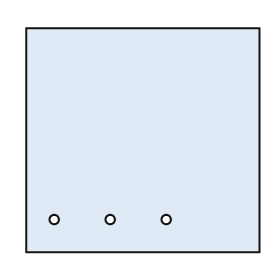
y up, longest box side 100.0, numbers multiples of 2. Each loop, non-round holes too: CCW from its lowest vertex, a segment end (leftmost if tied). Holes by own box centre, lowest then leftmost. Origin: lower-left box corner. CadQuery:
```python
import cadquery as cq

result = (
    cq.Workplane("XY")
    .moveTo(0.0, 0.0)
    .lineTo(100.0, 0.0)
    .lineTo(100.0, 96.0)
    .lineTo(0.0, 96.0)
    .close()
    .moveTo(12.0, 14.0)
    .circle(2.0)
    .moveTo(36.0, 14.0)
    .circle(2.0)
    .moveTo(60.0, 14.0)
    .circle(2.0)
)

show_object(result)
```